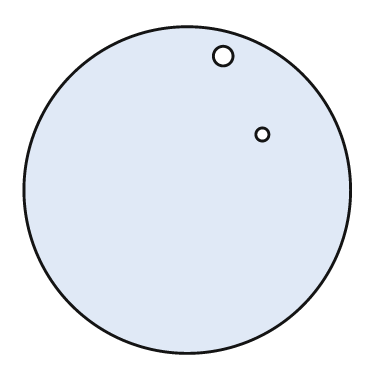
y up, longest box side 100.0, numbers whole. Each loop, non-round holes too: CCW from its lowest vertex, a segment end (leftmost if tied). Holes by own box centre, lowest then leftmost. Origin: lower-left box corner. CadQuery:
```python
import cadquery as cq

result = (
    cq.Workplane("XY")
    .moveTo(50.0, 50.0)
    .circle(50.0)
    .moveTo(73.0, 67.0)
    .circle(2.0)
    .moveTo(61.0, 91.0)
    .circle(3.0)
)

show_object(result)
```